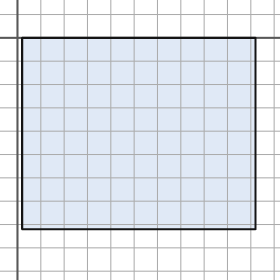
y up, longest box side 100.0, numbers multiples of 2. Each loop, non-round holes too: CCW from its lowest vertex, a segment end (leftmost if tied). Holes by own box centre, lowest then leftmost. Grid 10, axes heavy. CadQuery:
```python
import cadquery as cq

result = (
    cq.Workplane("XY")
    .moveTo(2.0, -82.0)
    .lineTo(102.0, -82.0)
    .lineTo(102.0, 0.0)
    .lineTo(2.0, 0.0)
    .close()
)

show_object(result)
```